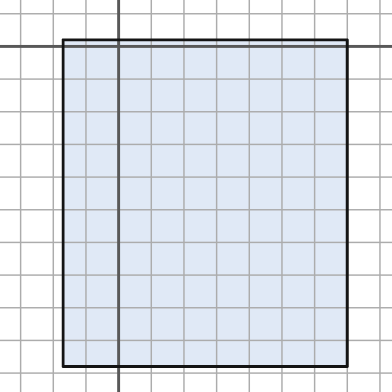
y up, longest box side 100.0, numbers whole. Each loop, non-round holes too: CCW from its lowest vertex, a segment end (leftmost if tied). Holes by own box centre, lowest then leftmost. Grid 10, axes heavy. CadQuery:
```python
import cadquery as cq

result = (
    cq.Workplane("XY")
    .moveTo(-17.0, -98.0)
    .lineTo(70.0, -98.0)
    .lineTo(70.0, 2.0)
    .lineTo(-17.0, 2.0)
    .close()
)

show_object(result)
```